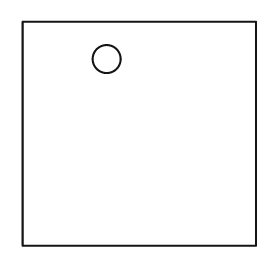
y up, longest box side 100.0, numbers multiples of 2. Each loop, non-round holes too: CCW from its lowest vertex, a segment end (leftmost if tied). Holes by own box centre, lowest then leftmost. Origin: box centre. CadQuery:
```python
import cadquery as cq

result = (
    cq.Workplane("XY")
    .moveTo(-50.0, -48.0)
    .lineTo(50.0, -48.0)
    .lineTo(50.0, 48.0)
    .lineTo(-50.0, 48.0)
    .close()
    .moveTo(-14.0, 32.0)
    .circle(6.0)
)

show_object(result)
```